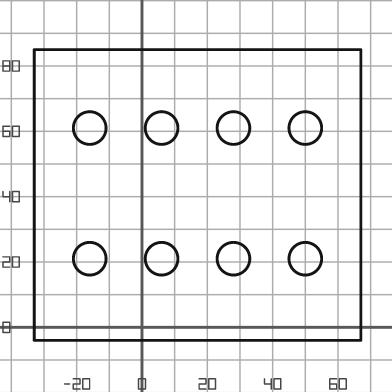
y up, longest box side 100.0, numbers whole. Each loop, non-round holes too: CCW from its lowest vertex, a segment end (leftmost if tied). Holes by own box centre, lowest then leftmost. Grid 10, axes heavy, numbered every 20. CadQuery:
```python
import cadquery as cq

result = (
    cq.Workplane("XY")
    .moveTo(-33.0, -4.0)
    .lineTo(67.0, -4.0)
    .lineTo(67.0, 85.0)
    .lineTo(-33.0, 85.0)
    .close()
    .moveTo(-16.0, 21.0)
    .circle(5.0)
    .moveTo(6.0, 21.0)
    .circle(5.0)
    .moveTo(28.0, 21.0)
    .circle(5.0)
    .moveTo(50.0, 21.0)
    .circle(5.0)
    .moveTo(-16.0, 61.0)
    .circle(5.0)
    .moveTo(6.0, 61.0)
    .circle(5.0)
    .moveTo(28.0, 61.0)
    .circle(5.0)
    .moveTo(50.0, 61.0)
    .circle(5.0)
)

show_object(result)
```